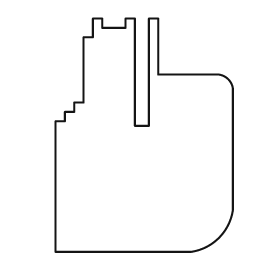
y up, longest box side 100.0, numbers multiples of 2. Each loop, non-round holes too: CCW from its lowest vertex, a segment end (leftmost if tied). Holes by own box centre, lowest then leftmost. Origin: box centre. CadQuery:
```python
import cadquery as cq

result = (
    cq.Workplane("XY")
    .moveTo(-38.0, -50.0)
    .lineTo(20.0, -50.0)
    .threePointArc((32.0, -44.0), (38.0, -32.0))
    .lineTo(38.0, 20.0)
    .threePointArc((36.0, 24.0), (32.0, 26.0))
    .lineTo(6.0, 26.0)
    .lineTo(6.0, 50.0)
    .lineTo(2.0, 50.0)
    .lineTo(2.0, 4.0)
    .lineTo(-4.0, 4.0)
    .lineTo(-4.0, 50.0)
    .lineTo(-8.0, 50.0)
    .lineTo(-8.0, 46.0)
    .lineTo(-18.0, 46.0)
    .lineTo(-18.0, 50.0)
    .lineTo(-22.0, 50.0)
    .lineTo(-22.0, 42.0)
    .lineTo(-26.0, 42.0)
    .lineTo(-26.0, 14.0)
    .lineTo(-30.0, 14.0)
    .lineTo(-30.0, 10.0)
    .lineTo(-34.0, 10.0)
    .lineTo(-34.0, 6.0)
    .lineTo(-38.0, 6.0)
    .close()
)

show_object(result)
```